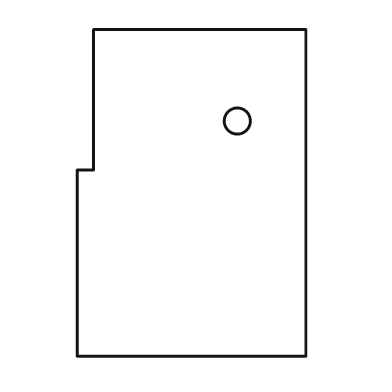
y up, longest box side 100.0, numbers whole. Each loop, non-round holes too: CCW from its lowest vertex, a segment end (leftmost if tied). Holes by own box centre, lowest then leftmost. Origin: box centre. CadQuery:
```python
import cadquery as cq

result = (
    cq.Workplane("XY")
    .moveTo(-35.0, -50.0)
    .lineTo(35.0, -50.0)
    .lineTo(35.0, 50.0)
    .lineTo(-30.0, 50.0)
    .lineTo(-30.0, 7.0)
    .lineTo(-35.0, 7.0)
    .close()
    .moveTo(14.0, 22.0)
    .circle(4.0)
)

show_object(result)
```